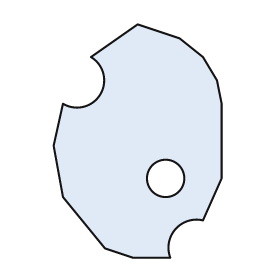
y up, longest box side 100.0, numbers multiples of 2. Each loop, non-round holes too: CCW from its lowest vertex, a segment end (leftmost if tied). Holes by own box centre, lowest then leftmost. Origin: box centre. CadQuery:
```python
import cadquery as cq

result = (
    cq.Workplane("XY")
    .moveTo(-2.0, -50.0)
    .lineTo(14.0, -50.0)
    .threePointArc((16.0, -38.0), (28.0, -34.0))
    .lineTo(36.0, -16.0)
    .lineTo(36.0, 16.0)
    .lineTo(34.0, 26.0)
    .lineTo(28.0, 36.0)
    .lineTo(18.0, 44.0)
    .lineTo(0.0, 50.0)
    .lineTo(-20.0, 36.0)
    .threePointArc((-16.0, 20.0), (-32.0, 16.0))
    .lineTo(-36.0, -2.0)
    .lineTo(-32.0, -24.0)
    .lineTo(-14.0, -46.0)
    .close()
    .moveTo(12.0, -16.0)
    .circle(8.0)
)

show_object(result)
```